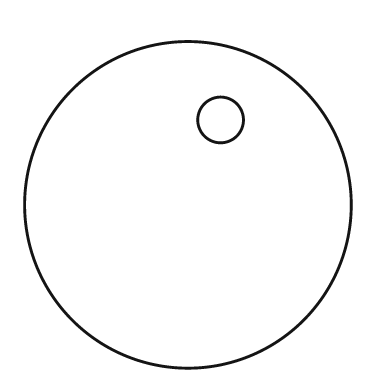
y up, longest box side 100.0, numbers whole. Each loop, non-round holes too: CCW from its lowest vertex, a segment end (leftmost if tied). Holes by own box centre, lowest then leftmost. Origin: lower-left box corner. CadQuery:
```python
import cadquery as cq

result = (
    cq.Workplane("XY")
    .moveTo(50.0, 50.0)
    .circle(50.0)
    .moveTo(60.0, 76.0)
    .circle(7.0)
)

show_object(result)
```